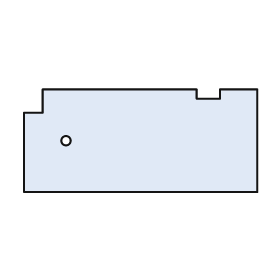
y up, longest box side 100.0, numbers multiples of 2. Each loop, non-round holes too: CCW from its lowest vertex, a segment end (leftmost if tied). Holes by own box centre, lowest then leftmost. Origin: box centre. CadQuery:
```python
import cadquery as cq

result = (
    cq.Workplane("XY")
    .moveTo(-50.0, -22.0)
    .lineTo(50.0, -22.0)
    .lineTo(50.0, 22.0)
    .lineTo(34.0, 22.0)
    .lineTo(34.0, 18.0)
    .lineTo(24.0, 18.0)
    .lineTo(24.0, 22.0)
    .lineTo(-42.0, 22.0)
    .lineTo(-42.0, 12.0)
    .lineTo(-50.0, 12.0)
    .close()
    .moveTo(-32.0, 0.0)
    .circle(2.0)
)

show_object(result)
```